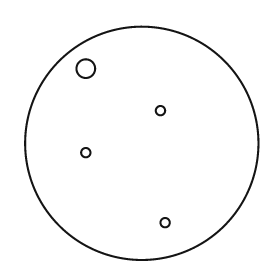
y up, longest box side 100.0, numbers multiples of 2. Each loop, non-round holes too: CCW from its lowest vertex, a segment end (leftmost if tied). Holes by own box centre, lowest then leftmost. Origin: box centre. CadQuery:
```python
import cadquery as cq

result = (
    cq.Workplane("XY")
    .moveTo(0.0, 0.0)
    .circle(50.0)
    .moveTo(10.0, -34.0)
    .circle(2.0)
    .moveTo(-24.0, -4.0)
    .circle(2.0)
    .moveTo(8.0, 14.0)
    .circle(2.0)
    .moveTo(-24.0, 32.0)
    .circle(4.0)
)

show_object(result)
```